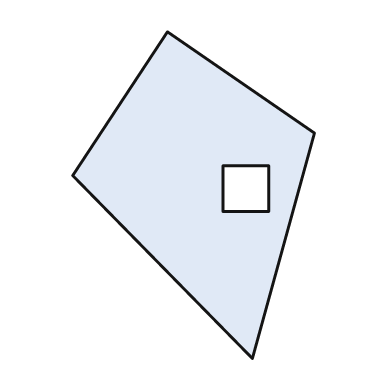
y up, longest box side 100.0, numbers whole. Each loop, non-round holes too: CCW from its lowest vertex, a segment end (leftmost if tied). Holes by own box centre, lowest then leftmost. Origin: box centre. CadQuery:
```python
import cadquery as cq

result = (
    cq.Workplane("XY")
    .moveTo(18.0, -50.0)
    .lineTo(37.0, 19.0)
    .lineTo(-8.0, 50.0)
    .lineTo(-37.0, 6.0)
    .close()
    .moveTo(9.0, -5.0)
    .lineTo(23.0, -5.0)
    .lineTo(23.0, 9.0)
    .lineTo(9.0, 9.0)
    .close()
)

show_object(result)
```